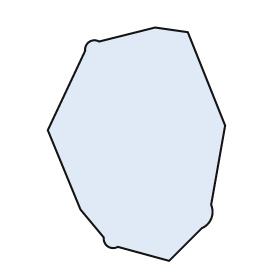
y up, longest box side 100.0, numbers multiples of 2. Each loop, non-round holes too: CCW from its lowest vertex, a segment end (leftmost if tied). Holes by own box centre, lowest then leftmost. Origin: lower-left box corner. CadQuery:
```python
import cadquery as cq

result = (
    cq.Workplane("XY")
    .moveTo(52.0, 0.0)
    .lineTo(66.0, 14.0)
    .threePointArc((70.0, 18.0), (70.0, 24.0))
    .lineTo(76.0, 58.0)
    .lineTo(60.0, 98.0)
    .lineTo(46.0, 100.0)
    .lineTo(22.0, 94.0)
    .threePointArc((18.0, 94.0), (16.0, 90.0))
    .lineTo(0.0, 56.0)
    .lineTo(14.0, 22.0)
    .lineTo(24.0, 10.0)
    .threePointArc((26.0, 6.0), (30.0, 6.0))
    .close()
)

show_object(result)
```